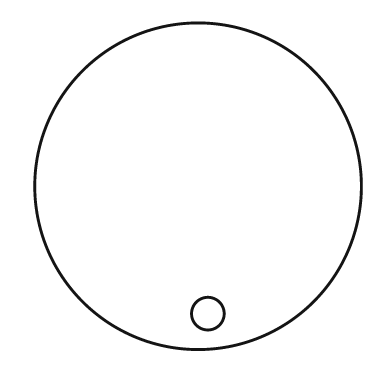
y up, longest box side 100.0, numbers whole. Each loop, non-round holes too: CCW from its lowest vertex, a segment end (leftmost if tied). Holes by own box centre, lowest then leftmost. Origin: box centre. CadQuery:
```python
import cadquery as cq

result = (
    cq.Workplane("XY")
    .moveTo(0.0, 0.0)
    .circle(50.0)
    .moveTo(3.0, -39.0)
    .circle(5.0)
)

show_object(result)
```